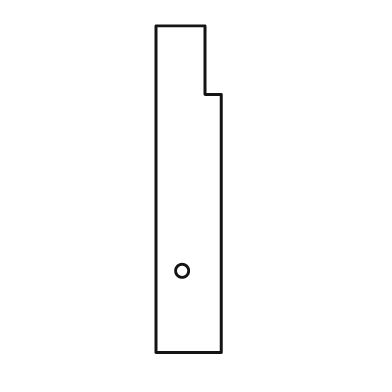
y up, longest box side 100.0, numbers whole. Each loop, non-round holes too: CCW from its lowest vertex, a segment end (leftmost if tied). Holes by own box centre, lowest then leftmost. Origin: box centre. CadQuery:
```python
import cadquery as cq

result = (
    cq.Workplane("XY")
    .moveTo(-10.0, -50.0)
    .lineTo(10.0, -50.0)
    .lineTo(10.0, 29.0)
    .lineTo(5.0, 29.0)
    .lineTo(5.0, 50.0)
    .lineTo(-10.0, 50.0)
    .close()
    .moveTo(-2.0, -25.0)
    .circle(2.0)
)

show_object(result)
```